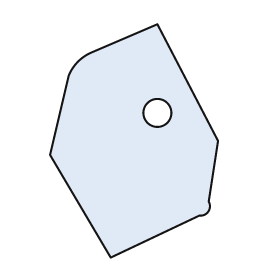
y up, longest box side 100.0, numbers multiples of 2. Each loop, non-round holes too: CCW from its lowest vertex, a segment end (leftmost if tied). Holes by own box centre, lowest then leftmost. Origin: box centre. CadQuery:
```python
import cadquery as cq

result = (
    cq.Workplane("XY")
    .moveTo(-10.0, -50.0)
    .lineTo(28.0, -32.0)
    .threePointArc((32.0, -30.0), (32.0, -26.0))
    .lineTo(36.0, 0.0)
    .lineTo(10.0, 50.0)
    .lineTo(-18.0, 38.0)
    .threePointArc((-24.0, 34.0), (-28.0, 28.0))
    .lineTo(-36.0, -6.0)
    .close()
    .moveTo(10.0, 12.0)
    .circle(6.0)
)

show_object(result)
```